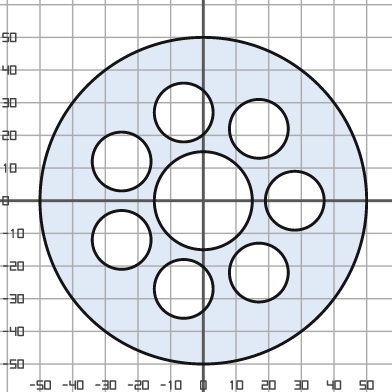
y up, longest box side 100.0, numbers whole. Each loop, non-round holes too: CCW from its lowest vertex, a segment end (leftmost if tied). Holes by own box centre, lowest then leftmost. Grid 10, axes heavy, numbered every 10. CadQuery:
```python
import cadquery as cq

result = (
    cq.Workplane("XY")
    .moveTo(0.0, 0.0)
    .circle(50.0)
    .moveTo(-6.0, -27.0)
    .circle(9.0)
    .moveTo(17.0, -22.0)
    .circle(9.0)
    .moveTo(-25.0, -12.0)
    .circle(9.0)
    .moveTo(0.0, 0.0)
    .circle(15.0)
    .moveTo(28.0, 0.0)
    .circle(9.0)
    .moveTo(-25.0, 12.0)
    .circle(9.0)
    .moveTo(17.0, 22.0)
    .circle(9.0)
    .moveTo(-6.0, 27.0)
    .circle(9.0)
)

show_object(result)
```